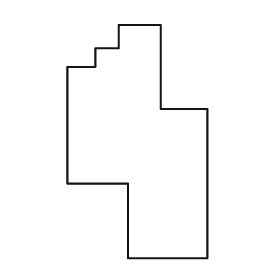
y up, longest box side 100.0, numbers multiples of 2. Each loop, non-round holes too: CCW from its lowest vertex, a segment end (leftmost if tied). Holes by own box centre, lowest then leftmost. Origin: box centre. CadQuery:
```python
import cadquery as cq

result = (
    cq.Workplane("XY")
    .moveTo(-4.0, -50.0)
    .lineTo(30.0, -50.0)
    .lineTo(30.0, 14.0)
    .lineTo(10.0, 14.0)
    .lineTo(10.0, 50.0)
    .lineTo(-8.0, 50.0)
    .lineTo(-8.0, 40.0)
    .lineTo(-18.0, 40.0)
    .lineTo(-18.0, 32.0)
    .lineTo(-30.0, 32.0)
    .lineTo(-30.0, -18.0)
    .lineTo(-4.0, -18.0)
    .close()
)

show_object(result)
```